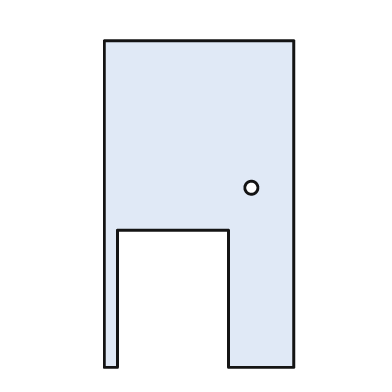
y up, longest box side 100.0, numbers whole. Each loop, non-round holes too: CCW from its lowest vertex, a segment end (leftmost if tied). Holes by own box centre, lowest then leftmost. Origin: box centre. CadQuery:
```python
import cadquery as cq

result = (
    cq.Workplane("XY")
    .moveTo(-29.0, -50.0)
    .lineTo(-25.0, -50.0)
    .lineTo(-25.0, -8.0)
    .lineTo(9.0, -8.0)
    .lineTo(9.0, -50.0)
    .lineTo(29.0, -50.0)
    .lineTo(29.0, 50.0)
    .lineTo(-29.0, 50.0)
    .close()
    .moveTo(16.0, 5.0)
    .circle(2.0)
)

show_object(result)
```